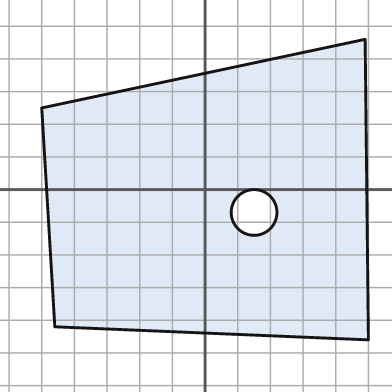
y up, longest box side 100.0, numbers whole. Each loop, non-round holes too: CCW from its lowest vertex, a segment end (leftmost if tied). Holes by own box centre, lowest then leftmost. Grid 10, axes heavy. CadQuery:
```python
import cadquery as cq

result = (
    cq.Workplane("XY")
    .moveTo(50.0, -46.0)
    .lineTo(49.0, 46.0)
    .lineTo(-50.0, 25.0)
    .lineTo(-46.0, -42.0)
    .close()
    .moveTo(15.0, -7.0)
    .circle(7.0)
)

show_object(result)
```